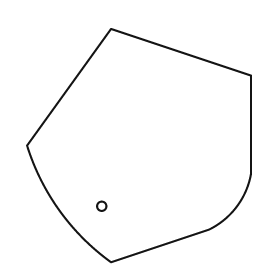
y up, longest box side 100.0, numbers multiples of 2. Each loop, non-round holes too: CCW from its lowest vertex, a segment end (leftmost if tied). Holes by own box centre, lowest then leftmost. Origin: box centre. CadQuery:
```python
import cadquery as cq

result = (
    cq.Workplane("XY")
    .moveTo(-12.0, -50.0)
    .lineTo(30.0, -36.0)
    .threePointArc((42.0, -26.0), (48.0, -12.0))
    .lineTo(48.0, 30.0)
    .lineTo(-12.0, 50.0)
    .lineTo(-48.0, 0.0)
    .threePointArc((-34.0, -28.0), (-12.0, -50.0))
    .close()
    .moveTo(-16.0, -26.0)
    .circle(2.0)
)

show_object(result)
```